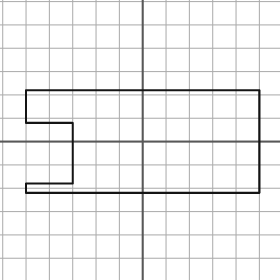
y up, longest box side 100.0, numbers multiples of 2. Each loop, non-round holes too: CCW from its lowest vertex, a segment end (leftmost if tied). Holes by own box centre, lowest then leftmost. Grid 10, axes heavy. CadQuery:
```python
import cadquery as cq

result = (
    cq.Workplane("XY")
    .moveTo(-50.0, -22.0)
    .lineTo(50.0, -22.0)
    .lineTo(50.0, 22.0)
    .lineTo(-50.0, 22.0)
    .lineTo(-50.0, 8.0)
    .lineTo(-30.0, 8.0)
    .lineTo(-30.0, -18.0)
    .lineTo(-50.0, -18.0)
    .close()
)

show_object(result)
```